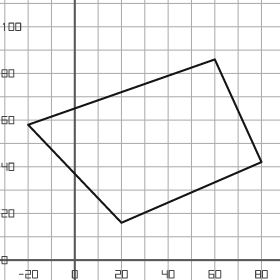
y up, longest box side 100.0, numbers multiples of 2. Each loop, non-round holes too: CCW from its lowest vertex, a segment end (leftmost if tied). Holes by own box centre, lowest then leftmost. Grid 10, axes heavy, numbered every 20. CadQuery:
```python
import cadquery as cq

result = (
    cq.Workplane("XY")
    .moveTo(20.0, 16.0)
    .lineTo(80.0, 42.0)
    .lineTo(60.0, 86.0)
    .lineTo(-20.0, 58.0)
    .close()
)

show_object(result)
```